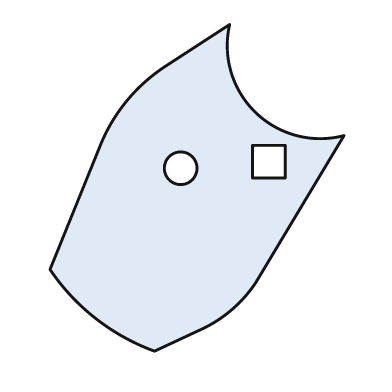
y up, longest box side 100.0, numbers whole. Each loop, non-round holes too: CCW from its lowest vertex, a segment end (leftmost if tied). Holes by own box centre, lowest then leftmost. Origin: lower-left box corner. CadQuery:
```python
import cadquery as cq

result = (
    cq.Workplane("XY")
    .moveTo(32.0, 0.0)
    .lineTo(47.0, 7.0)
    .threePointArc((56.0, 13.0), (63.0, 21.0))
    .lineTo(90.0, 66.0)
    .threePointArc((63.0, 73.0), (55.0, 100.0))
    .lineTo(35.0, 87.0)
    .threePointArc((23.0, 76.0), (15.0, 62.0))
    .lineTo(0.0, 25.0)
    .threePointArc((14.0, 10.0), (32.0, 0.0))
    .close()
    .moveTo(40.0, 56.0)
    .circle(5.0)
    .moveTo(62.0, 53.0)
    .lineTo(72.0, 53.0)
    .lineTo(72.0, 63.0)
    .lineTo(62.0, 63.0)
    .close()
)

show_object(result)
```